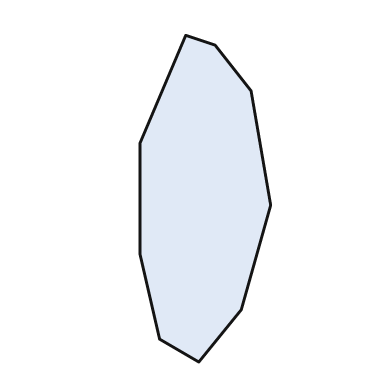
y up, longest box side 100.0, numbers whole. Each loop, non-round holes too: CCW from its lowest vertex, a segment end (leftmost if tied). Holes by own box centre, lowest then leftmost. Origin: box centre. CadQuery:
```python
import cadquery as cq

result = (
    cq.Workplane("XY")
    .moveTo(-2.0, -50.0)
    .lineTo(11.0, -34.0)
    .lineTo(20.0, -2.0)
    .lineTo(14.0, 33.0)
    .lineTo(3.0, 47.0)
    .lineTo(-6.0, 50.0)
    .lineTo(-20.0, 17.0)
    .lineTo(-20.0, -17.0)
    .lineTo(-14.0, -43.0)
    .close()
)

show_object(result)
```